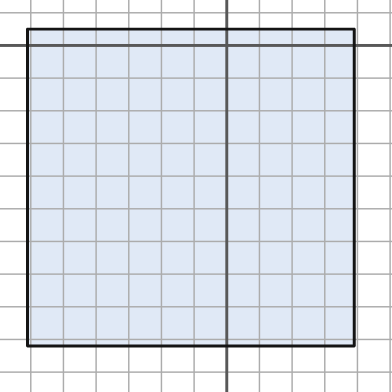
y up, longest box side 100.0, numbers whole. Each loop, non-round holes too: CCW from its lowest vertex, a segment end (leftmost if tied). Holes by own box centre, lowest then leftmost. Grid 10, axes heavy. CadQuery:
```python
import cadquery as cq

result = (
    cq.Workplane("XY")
    .moveTo(-61.0, -92.0)
    .lineTo(39.0, -92.0)
    .lineTo(39.0, 5.0)
    .lineTo(-61.0, 5.0)
    .close()
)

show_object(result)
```